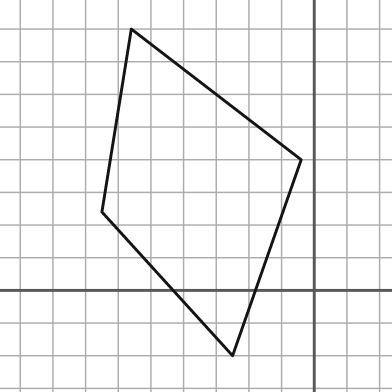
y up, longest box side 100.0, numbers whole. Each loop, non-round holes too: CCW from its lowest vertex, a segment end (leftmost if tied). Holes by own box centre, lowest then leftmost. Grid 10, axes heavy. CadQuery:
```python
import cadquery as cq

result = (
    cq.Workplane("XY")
    .moveTo(-25.0, -20.0)
    .lineTo(-4.0, 40.0)
    .lineTo(-56.0, 80.0)
    .lineTo(-65.0, 24.0)
    .close()
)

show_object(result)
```